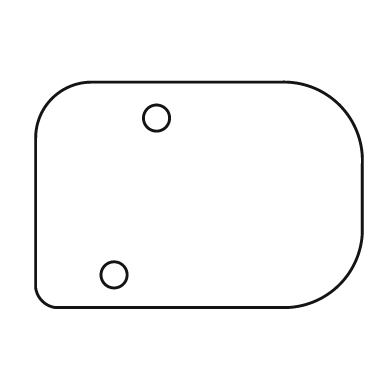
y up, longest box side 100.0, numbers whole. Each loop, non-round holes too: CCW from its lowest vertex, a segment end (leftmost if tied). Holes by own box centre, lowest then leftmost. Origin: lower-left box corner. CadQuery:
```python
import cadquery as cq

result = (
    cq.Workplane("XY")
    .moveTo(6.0, 0.0)
    .lineTo(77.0, 0.0)
    .threePointArc((93.0, 7.0), (100.0, 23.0))
    .lineTo(100.0, 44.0)
    .threePointArc((93.0, 62.0), (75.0, 69.0))
    .lineTo(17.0, 69.0)
    .threePointArc((5.0, 64.0), (0.0, 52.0))
    .lineTo(0.0, 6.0)
    .threePointArc((2.0, 2.0), (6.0, 0.0))
    .close()
    .moveTo(24.0, 10.0)
    .circle(4.0)
    .moveTo(37.0, 58.0)
    .circle(4.0)
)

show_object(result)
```